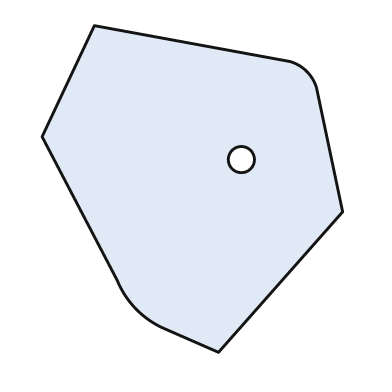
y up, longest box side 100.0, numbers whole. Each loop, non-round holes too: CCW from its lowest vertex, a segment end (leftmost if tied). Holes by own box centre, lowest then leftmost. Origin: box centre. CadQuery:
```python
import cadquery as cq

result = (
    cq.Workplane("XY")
    .moveTo(8.0, -50.0)
    .lineTo(46.0, -7.0)
    .lineTo(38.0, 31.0)
    .threePointArc((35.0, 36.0), (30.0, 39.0))
    .lineTo(-30.0, 50.0)
    .lineTo(-46.0, 16.0)
    .lineTo(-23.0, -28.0)
    .threePointArc((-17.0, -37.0), (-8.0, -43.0))
    .close()
    .moveTo(15.0, 9.0)
    .circle(4.0)
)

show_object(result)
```